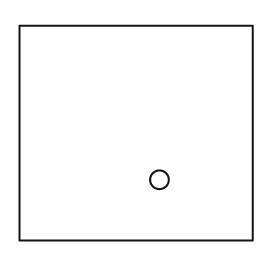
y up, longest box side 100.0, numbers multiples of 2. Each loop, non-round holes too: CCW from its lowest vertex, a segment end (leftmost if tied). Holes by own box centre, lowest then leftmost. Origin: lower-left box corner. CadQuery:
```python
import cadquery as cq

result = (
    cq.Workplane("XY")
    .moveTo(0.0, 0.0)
    .lineTo(100.0, 0.0)
    .lineTo(100.0, 92.0)
    .lineTo(0.0, 92.0)
    .close()
    .moveTo(60.0, 26.0)
    .circle(4.0)
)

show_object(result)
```